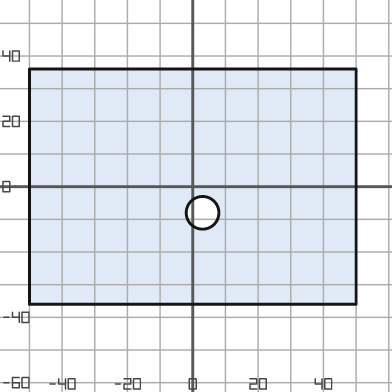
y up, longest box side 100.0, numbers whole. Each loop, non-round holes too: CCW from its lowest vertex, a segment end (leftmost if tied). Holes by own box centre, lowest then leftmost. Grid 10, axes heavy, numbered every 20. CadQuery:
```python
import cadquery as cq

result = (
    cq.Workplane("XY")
    .moveTo(-50.0, -36.0)
    .lineTo(50.0, -36.0)
    .lineTo(50.0, 36.0)
    .lineTo(-50.0, 36.0)
    .close()
    .moveTo(3.0, -8.0)
    .circle(5.0)
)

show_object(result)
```